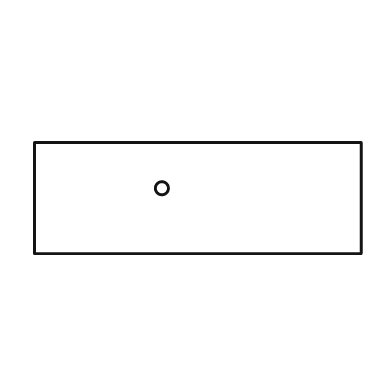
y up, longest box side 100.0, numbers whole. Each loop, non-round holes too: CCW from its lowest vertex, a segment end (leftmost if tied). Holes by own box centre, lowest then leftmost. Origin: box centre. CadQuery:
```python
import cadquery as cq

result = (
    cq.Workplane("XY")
    .moveTo(-50.0, -17.0)
    .lineTo(50.0, -17.0)
    .lineTo(50.0, 17.0)
    .lineTo(-50.0, 17.0)
    .close()
    .moveTo(-11.0, 3.0)
    .circle(2.0)
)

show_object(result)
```